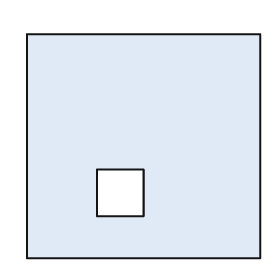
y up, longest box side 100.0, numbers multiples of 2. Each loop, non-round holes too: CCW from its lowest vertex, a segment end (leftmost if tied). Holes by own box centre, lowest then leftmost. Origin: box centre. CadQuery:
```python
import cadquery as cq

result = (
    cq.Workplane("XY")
    .moveTo(-50.0, -48.0)
    .lineTo(50.0, -48.0)
    .lineTo(50.0, 48.0)
    .lineTo(-50.0, 48.0)
    .close()
    .moveTo(-20.0, -30.0)
    .lineTo(0.0, -30.0)
    .lineTo(0.0, -10.0)
    .lineTo(-20.0, -10.0)
    .close()
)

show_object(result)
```